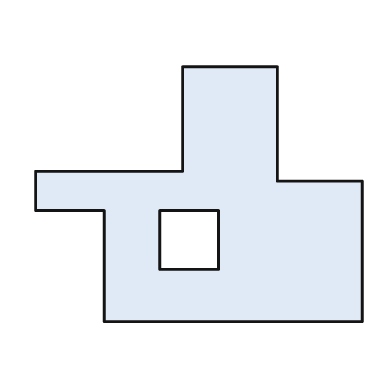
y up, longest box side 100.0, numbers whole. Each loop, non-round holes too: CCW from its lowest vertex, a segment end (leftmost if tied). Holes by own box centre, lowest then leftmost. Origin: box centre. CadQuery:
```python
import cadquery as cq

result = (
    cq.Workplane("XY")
    .moveTo(-29.0, -39.0)
    .lineTo(50.0, -39.0)
    .lineTo(50.0, 4.0)
    .lineTo(24.0, 4.0)
    .lineTo(24.0, 39.0)
    .lineTo(-5.0, 39.0)
    .lineTo(-5.0, 7.0)
    .lineTo(-50.0, 7.0)
    .lineTo(-50.0, -5.0)
    .lineTo(-29.0, -5.0)
    .close()
    .moveTo(-12.0, -23.0)
    .lineTo(6.0, -23.0)
    .lineTo(6.0, -5.0)
    .lineTo(-12.0, -5.0)
    .close()
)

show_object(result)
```